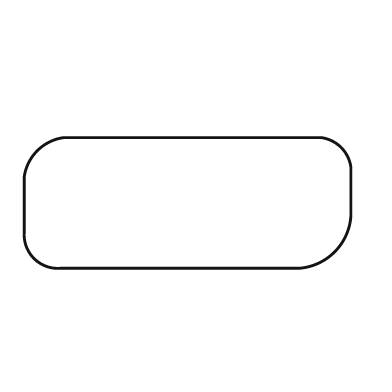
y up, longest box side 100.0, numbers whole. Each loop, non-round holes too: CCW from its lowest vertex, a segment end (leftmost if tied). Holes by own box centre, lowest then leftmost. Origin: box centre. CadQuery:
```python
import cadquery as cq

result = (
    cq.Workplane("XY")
    .moveTo(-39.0, -20.0)
    .lineTo(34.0, -20.0)
    .threePointArc((45.0, -15.0), (50.0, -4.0))
    .lineTo(50.0, 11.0)
    .threePointArc((47.0, 17.0), (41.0, 20.0))
    .lineTo(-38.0, 20.0)
    .threePointArc((-46.0, 16.0), (-50.0, 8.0))
    .lineTo(-50.0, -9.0)
    .threePointArc((-47.0, -17.0), (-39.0, -20.0))
    .close()
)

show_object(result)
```